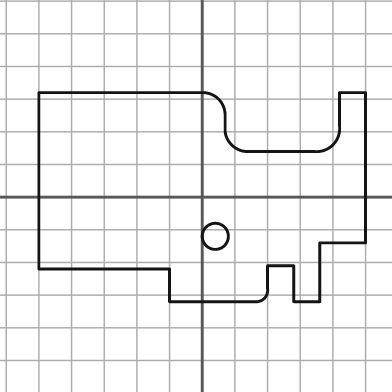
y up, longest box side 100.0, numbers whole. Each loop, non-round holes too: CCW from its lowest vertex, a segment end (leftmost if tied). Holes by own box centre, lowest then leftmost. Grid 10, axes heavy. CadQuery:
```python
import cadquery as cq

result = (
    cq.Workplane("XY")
    .moveTo(-10.0, -32.0)
    .lineTo(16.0, -32.0)
    .threePointArc((19.0, -31.0), (20.0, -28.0))
    .lineTo(20.0, -21.0)
    .lineTo(28.0, -21.0)
    .lineTo(28.0, -32.0)
    .lineTo(36.0, -32.0)
    .lineTo(36.0, -14.0)
    .lineTo(50.0, -14.0)
    .lineTo(50.0, 32.0)
    .lineTo(42.0, 32.0)
    .lineTo(42.0, 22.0)
    .threePointArc((40.0, 16.0), (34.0, 14.0))
    .lineTo(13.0, 14.0)
    .threePointArc((9.0, 16.0), (7.0, 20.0))
    .lineTo(7.0, 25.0)
    .threePointArc((5.0, 30.0), (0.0, 32.0))
    .lineTo(-50.0, 32.0)
    .lineTo(-50.0, -22.0)
    .lineTo(-10.0, -22.0)
    .close()
    .moveTo(4.0, -12.0)
    .circle(4.0)
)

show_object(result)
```